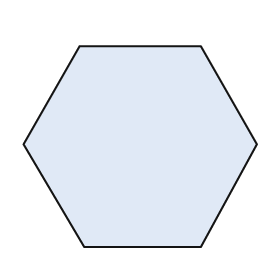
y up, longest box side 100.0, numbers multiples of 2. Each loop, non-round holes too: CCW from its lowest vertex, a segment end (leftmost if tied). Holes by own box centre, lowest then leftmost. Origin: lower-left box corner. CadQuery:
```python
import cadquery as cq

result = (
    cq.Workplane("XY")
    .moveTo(26.0, 0.0)
    .lineTo(76.0, 0.0)
    .lineTo(100.0, 44.0)
    .lineTo(76.0, 86.0)
    .lineTo(24.0, 86.0)
    .lineTo(0.0, 44.0)
    .close()
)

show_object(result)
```